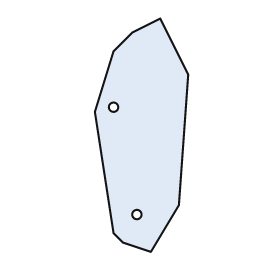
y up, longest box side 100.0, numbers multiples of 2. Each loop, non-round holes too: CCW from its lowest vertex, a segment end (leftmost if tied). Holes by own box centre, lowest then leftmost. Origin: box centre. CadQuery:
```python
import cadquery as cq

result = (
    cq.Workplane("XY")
    .moveTo(4.0, -50.0)
    .lineTo(16.0, -30.0)
    .lineTo(20.0, 26.0)
    .lineTo(8.0, 50.0)
    .lineTo(-4.0, 44.0)
    .lineTo(-12.0, 36.0)
    .lineTo(-20.0, 10.0)
    .lineTo(-12.0, -42.0)
    .lineTo(-8.0, -46.0)
    .close()
    .moveTo(-2.0, -34.0)
    .circle(2.0)
    .moveTo(-12.0, 12.0)
    .circle(2.0)
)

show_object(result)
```